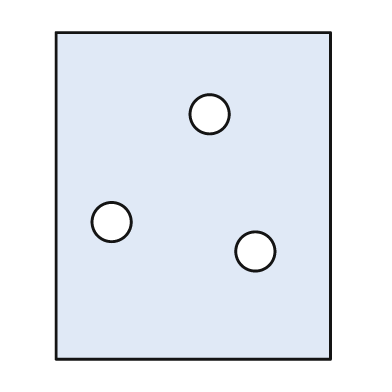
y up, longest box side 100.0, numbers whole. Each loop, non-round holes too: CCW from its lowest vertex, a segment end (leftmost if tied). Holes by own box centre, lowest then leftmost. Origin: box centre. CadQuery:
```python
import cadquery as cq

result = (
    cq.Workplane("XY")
    .moveTo(-42.0, -50.0)
    .lineTo(42.0, -50.0)
    .lineTo(42.0, 50.0)
    .lineTo(-42.0, 50.0)
    .close()
    .moveTo(19.0, -17.0)
    .circle(6.0)
    .moveTo(-25.0, -8.0)
    .circle(6.0)
    .moveTo(5.0, 25.0)
    .circle(6.0)
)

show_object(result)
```